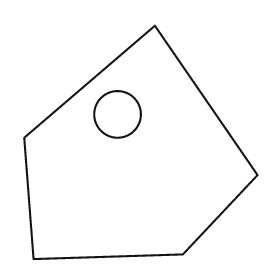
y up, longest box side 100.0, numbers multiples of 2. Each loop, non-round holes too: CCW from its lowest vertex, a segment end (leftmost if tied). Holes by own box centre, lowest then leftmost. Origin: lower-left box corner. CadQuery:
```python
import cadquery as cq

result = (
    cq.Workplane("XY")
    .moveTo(4.0, 0.0)
    .lineTo(68.0, 2.0)
    .lineTo(100.0, 36.0)
    .lineTo(56.0, 100.0)
    .lineTo(0.0, 52.0)
    .close()
    .moveTo(40.0, 62.0)
    .circle(10.0)
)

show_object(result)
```